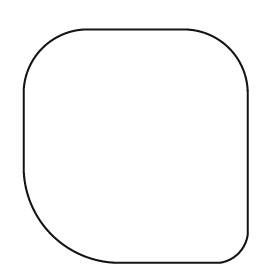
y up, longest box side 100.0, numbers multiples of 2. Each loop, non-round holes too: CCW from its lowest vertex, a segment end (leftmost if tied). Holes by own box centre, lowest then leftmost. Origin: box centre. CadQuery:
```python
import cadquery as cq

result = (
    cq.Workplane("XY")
    .moveTo(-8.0, -50.0)
    .lineTo(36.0, -50.0)
    .threePointArc((44.0, -46.0), (48.0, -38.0))
    .lineTo(48.0, 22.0)
    .threePointArc((40.0, 42.0), (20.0, 50.0))
    .lineTo(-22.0, 50.0)
    .threePointArc((-40.0, 42.0), (-48.0, 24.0))
    .lineTo(-48.0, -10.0)
    .threePointArc((-36.0, -38.0), (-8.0, -50.0))
    .close()
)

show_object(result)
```